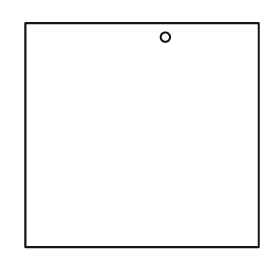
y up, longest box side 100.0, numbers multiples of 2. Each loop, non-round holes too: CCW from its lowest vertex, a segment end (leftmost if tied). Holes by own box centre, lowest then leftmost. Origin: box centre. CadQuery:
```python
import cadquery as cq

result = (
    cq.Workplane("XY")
    .moveTo(-50.0, -48.0)
    .lineTo(50.0, -48.0)
    .lineTo(50.0, 48.0)
    .lineTo(-50.0, 48.0)
    .close()
    .moveTo(10.0, 42.0)
    .circle(2.0)
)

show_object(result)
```